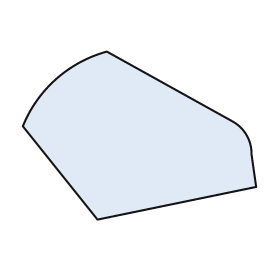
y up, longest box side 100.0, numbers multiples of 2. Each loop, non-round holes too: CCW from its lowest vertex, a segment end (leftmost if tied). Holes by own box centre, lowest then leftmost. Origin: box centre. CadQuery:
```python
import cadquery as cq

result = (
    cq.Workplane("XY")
    .moveTo(-18.0, -36.0)
    .lineTo(50.0, -22.0)
    .lineTo(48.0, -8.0)
    .threePointArc((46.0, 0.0), (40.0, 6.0))
    .lineTo(-14.0, 36.0)
    .threePointArc((-36.0, 24.0), (-50.0, 4.0))
    .close()
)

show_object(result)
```